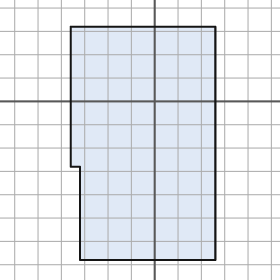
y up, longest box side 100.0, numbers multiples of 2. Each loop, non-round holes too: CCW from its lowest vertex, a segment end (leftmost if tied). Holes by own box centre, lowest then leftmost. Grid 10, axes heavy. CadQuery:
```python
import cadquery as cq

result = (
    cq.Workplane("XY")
    .moveTo(-32.0, -68.0)
    .lineTo(26.0, -68.0)
    .lineTo(26.0, 32.0)
    .lineTo(-36.0, 32.0)
    .lineTo(-36.0, -28.0)
    .lineTo(-32.0, -28.0)
    .close()
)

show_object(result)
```